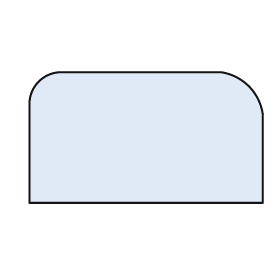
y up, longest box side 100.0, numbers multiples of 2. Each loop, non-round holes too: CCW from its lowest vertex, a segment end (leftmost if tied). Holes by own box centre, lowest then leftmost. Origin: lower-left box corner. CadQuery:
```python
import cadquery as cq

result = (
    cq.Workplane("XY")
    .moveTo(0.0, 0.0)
    .lineTo(100.0, 0.0)
    .lineTo(100.0, 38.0)
    .threePointArc((94.0, 50.0), (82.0, 56.0))
    .lineTo(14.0, 56.0)
    .threePointArc((4.0, 52.0), (0.0, 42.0))
    .close()
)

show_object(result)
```